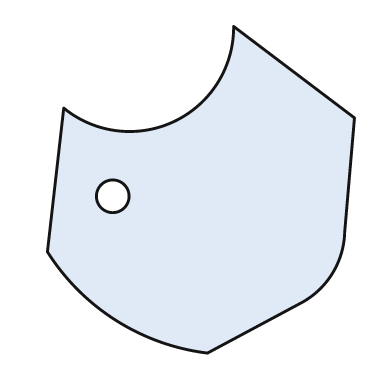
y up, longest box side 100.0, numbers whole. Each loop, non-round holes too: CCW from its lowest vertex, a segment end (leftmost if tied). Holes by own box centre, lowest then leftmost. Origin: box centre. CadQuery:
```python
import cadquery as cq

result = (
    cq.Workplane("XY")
    .moveTo(2.0, -50.0)
    .lineTo(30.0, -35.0)
    .threePointArc((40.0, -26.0), (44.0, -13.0))
    .lineTo(47.0, 22.0)
    .lineTo(10.0, 50.0)
    .threePointArc((-8.0, 21.0), (-42.0, 25.0))
    .lineTo(-47.0, -19.0)
    .threePointArc((-26.0, -40.0), (2.0, -50.0))
    .close()
    .moveTo(-27.0, -2.0)
    .circle(5.0)
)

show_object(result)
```